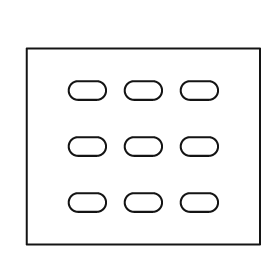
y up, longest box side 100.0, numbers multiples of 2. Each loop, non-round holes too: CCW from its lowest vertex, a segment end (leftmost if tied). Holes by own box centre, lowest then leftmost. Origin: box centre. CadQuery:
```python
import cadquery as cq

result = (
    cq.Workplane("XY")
    .moveTo(-50.0, -42.0)
    .lineTo(50.0, -42.0)
    .lineTo(50.0, 42.0)
    .lineTo(-50.0, 42.0)
    .close()
    .moveTo(-28.0, -28.0)
    .lineTo(-20.0, -28.0)
    .threePointArc((-16.0, -24.0), (-20.0, -20.0))
    .lineTo(-28.0, -20.0)
    .threePointArc((-32.0, -24.0), (-28.0, -28.0))
    .close()
    .moveTo(-4.0, -28.0)
    .lineTo(4.0, -28.0)
    .threePointArc((8.0, -24.0), (4.0, -20.0))
    .lineTo(-4.0, -20.0)
    .threePointArc((-8.0, -24.0), (-4.0, -28.0))
    .close()
    .moveTo(20.0, -28.0)
    .lineTo(28.0, -28.0)
    .threePointArc((32.0, -24.0), (28.0, -20.0))
    .lineTo(20.0, -20.0)
    .threePointArc((16.0, -24.0), (20.0, -28.0))
    .close()
    .moveTo(-28.0, -4.0)
    .lineTo(-20.0, -4.0)
    .threePointArc((-16.0, 0.0), (-20.0, 4.0))
    .lineTo(-28.0, 4.0)
    .threePointArc((-32.0, 0.0), (-28.0, -4.0))
    .close()
    .moveTo(-4.0, -4.0)
    .lineTo(4.0, -4.0)
    .threePointArc((8.0, 0.0), (4.0, 4.0))
    .lineTo(-4.0, 4.0)
    .threePointArc((-8.0, 0.0), (-4.0, -4.0))
    .close()
    .moveTo(20.0, -4.0)
    .lineTo(28.0, -4.0)
    .threePointArc((32.0, 0.0), (28.0, 4.0))
    .lineTo(20.0, 4.0)
    .threePointArc((16.0, 0.0), (20.0, -4.0))
    .close()
    .moveTo(-28.0, 20.0)
    .lineTo(-20.0, 20.0)
    .threePointArc((-16.0, 24.0), (-20.0, 28.0))
    .lineTo(-28.0, 28.0)
    .threePointArc((-32.0, 24.0), (-28.0, 20.0))
    .close()
    .moveTo(-4.0, 20.0)
    .lineTo(4.0, 20.0)
    .threePointArc((8.0, 24.0), (4.0, 28.0))
    .lineTo(-4.0, 28.0)
    .threePointArc((-8.0, 24.0), (-4.0, 20.0))
    .close()
    .moveTo(20.0, 20.0)
    .lineTo(28.0, 20.0)
    .threePointArc((32.0, 24.0), (28.0, 28.0))
    .lineTo(20.0, 28.0)
    .threePointArc((16.0, 24.0), (20.0, 20.0))
    .close()
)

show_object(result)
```